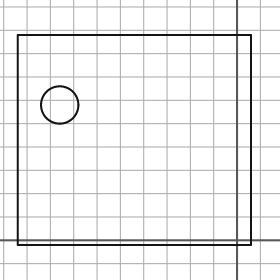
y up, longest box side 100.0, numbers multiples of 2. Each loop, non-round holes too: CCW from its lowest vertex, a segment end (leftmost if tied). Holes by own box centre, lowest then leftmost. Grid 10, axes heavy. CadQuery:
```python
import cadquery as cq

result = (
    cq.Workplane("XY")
    .moveTo(-94.0, -2.0)
    .lineTo(6.0, -2.0)
    .lineTo(6.0, 88.0)
    .lineTo(-94.0, 88.0)
    .close()
    .moveTo(-76.0, 58.0)
    .circle(8.0)
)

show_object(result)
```